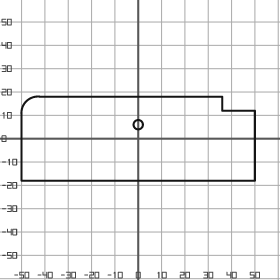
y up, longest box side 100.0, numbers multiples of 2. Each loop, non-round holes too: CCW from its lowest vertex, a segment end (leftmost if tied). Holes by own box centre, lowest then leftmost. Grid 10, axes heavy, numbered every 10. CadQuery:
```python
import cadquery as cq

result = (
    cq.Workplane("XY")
    .moveTo(-50.0, -18.0)
    .lineTo(50.0, -18.0)
    .lineTo(50.0, 12.0)
    .lineTo(36.0, 12.0)
    .lineTo(36.0, 18.0)
    .lineTo(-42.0, 18.0)
    .threePointArc((-48.0, 16.0), (-50.0, 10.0))
    .close()
    .moveTo(0.0, 6.0)
    .circle(2.0)
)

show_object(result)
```